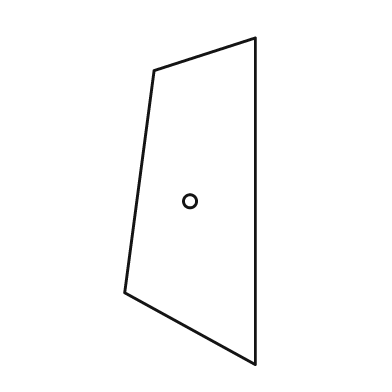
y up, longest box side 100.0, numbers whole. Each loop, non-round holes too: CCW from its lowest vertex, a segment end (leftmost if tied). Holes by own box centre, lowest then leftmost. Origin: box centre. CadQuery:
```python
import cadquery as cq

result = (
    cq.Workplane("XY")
    .moveTo(20.0, -50.0)
    .lineTo(20.0, 50.0)
    .lineTo(-11.0, 40.0)
    .lineTo(-20.0, -28.0)
    .close()
    .moveTo(0.0, 0.0)
    .circle(2.0)
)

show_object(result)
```